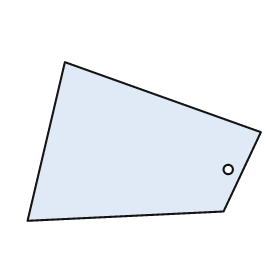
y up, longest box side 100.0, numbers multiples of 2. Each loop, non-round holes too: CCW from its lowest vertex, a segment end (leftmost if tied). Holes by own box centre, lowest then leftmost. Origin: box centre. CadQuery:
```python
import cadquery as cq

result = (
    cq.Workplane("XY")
    .moveTo(-50.0, -34.0)
    .lineTo(34.0, -30.0)
    .lineTo(50.0, 4.0)
    .lineTo(-34.0, 34.0)
    .close()
    .moveTo(36.0, -12.0)
    .circle(2.0)
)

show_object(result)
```